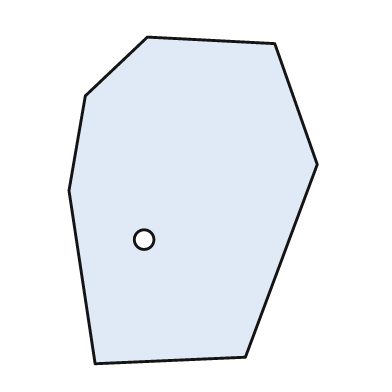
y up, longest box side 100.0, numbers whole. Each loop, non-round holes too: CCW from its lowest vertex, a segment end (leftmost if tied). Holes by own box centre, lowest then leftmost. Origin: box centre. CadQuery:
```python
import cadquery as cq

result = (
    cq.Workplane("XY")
    .moveTo(-30.0, -50.0)
    .lineTo(16.0, -48.0)
    .lineTo(38.0, 11.0)
    .lineTo(25.0, 48.0)
    .lineTo(-14.0, 50.0)
    .lineTo(-33.0, 32.0)
    .lineTo(-38.0, 3.0)
    .close()
    .moveTo(-15.0, -12.0)
    .circle(3.0)
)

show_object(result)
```